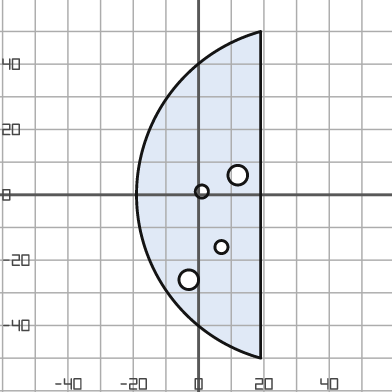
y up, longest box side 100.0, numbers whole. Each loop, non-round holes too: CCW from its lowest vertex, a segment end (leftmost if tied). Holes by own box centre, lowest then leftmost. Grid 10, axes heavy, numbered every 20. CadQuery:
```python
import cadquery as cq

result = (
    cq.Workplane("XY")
    .moveTo(19.0, -50.0)
    .lineTo(19.0, 50.0)
    .threePointArc((-19.0, 0.0), (19.0, -50.0))
    .close()
    .moveTo(-3.0, -26.0)
    .circle(3.0)
    .moveTo(7.0, -16.0)
    .circle(2.0)
    .moveTo(1.0, 1.0)
    .circle(2.0)
    .moveTo(12.0, 6.0)
    .circle(3.0)
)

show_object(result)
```